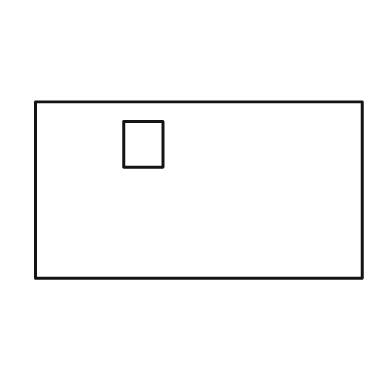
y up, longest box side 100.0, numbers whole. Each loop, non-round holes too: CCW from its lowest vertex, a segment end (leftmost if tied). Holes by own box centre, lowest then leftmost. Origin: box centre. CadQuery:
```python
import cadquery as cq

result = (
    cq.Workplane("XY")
    .moveTo(-50.0, -27.0)
    .lineTo(50.0, -27.0)
    .lineTo(50.0, 27.0)
    .lineTo(-50.0, 27.0)
    .close()
    .moveTo(-23.0, 7.0)
    .lineTo(-11.0, 7.0)
    .lineTo(-11.0, 21.0)
    .lineTo(-23.0, 21.0)
    .close()
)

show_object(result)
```